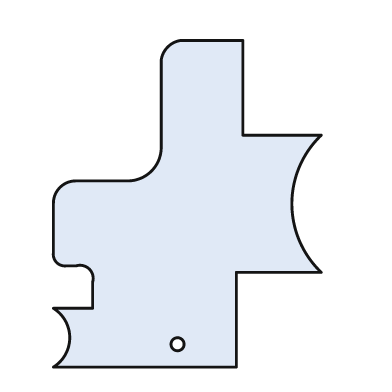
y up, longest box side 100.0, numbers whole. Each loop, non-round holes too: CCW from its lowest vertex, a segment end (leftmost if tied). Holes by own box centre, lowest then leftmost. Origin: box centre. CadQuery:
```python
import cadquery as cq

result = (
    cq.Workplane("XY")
    .moveTo(-41.0, -50.0)
    .lineTo(15.0, -50.0)
    .lineTo(15.0, -21.0)
    .lineTo(41.0, -21.0)
    .threePointArc((32.0, 0.0), (41.0, 21.0))
    .lineTo(17.0, 21.0)
    .lineTo(17.0, 50.0)
    .lineTo(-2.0, 50.0)
    .threePointArc((-6.0, 48.0), (-8.0, 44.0))
    .lineTo(-8.0, 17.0)
    .threePointArc((-11.0, 10.0), (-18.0, 7.0))
    .lineTo(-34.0, 7.0)
    .threePointArc((-39.0, 5.0), (-41.0, 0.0))
    .lineTo(-41.0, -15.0)
    .threePointArc((-40.0, -18.0), (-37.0, -19.0))
    .lineTo(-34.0, -19.0)
    .threePointArc((-30.0, -20.0), (-29.0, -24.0))
    .lineTo(-29.0, -32.0)
    .lineTo(-41.0, -32.0)
    .threePointArc((-36.0, -41.0), (-41.0, -50.0))
    .close()
    .moveTo(-3.0, -43.0)
    .circle(2.0)
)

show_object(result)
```